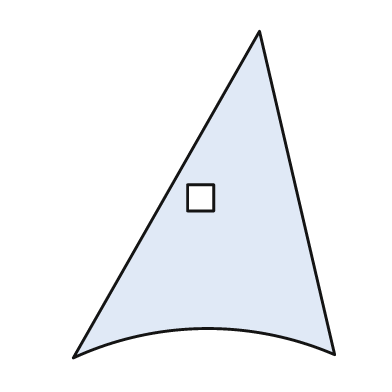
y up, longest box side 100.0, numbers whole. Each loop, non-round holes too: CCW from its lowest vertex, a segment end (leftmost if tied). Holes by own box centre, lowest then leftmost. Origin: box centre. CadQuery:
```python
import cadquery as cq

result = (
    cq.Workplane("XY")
    .moveTo(-40.0, -50.0)
    .threePointArc((0.0, -41.0), (40.0, -49.0))
    .lineTo(17.0, 50.0)
    .close()
    .moveTo(-5.0, -5.0)
    .lineTo(3.0, -5.0)
    .lineTo(3.0, 3.0)
    .lineTo(-5.0, 3.0)
    .close()
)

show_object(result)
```